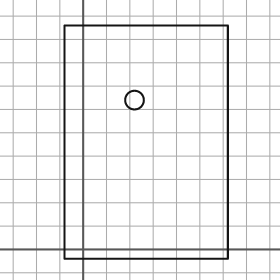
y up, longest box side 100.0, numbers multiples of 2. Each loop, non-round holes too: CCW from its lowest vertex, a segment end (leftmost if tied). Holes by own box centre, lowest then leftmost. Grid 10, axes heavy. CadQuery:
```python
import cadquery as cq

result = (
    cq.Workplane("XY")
    .moveTo(-8.0, -4.0)
    .lineTo(62.0, -4.0)
    .lineTo(62.0, 96.0)
    .lineTo(-8.0, 96.0)
    .close()
    .moveTo(22.0, 64.0)
    .circle(4.0)
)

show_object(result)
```